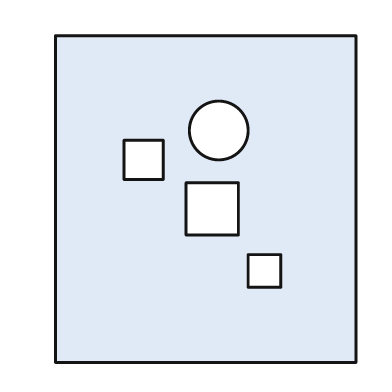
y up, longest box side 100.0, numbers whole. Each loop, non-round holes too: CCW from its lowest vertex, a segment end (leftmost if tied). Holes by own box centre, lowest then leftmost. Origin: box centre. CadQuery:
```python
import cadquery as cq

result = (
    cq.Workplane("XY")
    .moveTo(-46.0, -50.0)
    .lineTo(46.0, -50.0)
    .lineTo(46.0, 50.0)
    .lineTo(-46.0, 50.0)
    .close()
    .moveTo(13.0, -27.0)
    .lineTo(23.0, -27.0)
    .lineTo(23.0, -17.0)
    .lineTo(13.0, -17.0)
    .close()
    .moveTo(-6.0, -11.0)
    .lineTo(10.0, -11.0)
    .lineTo(10.0, 5.0)
    .lineTo(-6.0, 5.0)
    .close()
    .moveTo(-25.0, 6.0)
    .lineTo(-13.0, 6.0)
    .lineTo(-13.0, 18.0)
    .lineTo(-25.0, 18.0)
    .close()
    .moveTo(4.0, 21.0)
    .circle(9.0)
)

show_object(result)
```